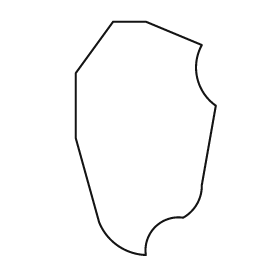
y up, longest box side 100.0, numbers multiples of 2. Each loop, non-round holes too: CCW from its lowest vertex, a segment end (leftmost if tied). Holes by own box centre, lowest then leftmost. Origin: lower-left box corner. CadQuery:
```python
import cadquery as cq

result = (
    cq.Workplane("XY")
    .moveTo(30.0, 0.0)
    .threePointArc((34.0, 12.0), (46.0, 16.0))
    .threePointArc((52.0, 22.0), (54.0, 30.0))
    .lineTo(60.0, 64.0)
    .threePointArc((52.0, 76.0), (54.0, 90.0))
    .lineTo(30.0, 100.0)
    .lineTo(16.0, 100.0)
    .lineTo(0.0, 78.0)
    .lineTo(0.0, 50.0)
    .lineTo(10.0, 14.0)
    .threePointArc((18.0, 4.0), (30.0, 0.0))
    .close()
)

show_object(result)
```